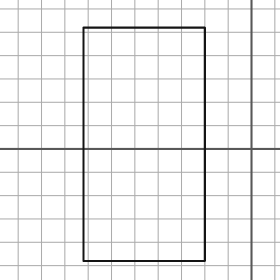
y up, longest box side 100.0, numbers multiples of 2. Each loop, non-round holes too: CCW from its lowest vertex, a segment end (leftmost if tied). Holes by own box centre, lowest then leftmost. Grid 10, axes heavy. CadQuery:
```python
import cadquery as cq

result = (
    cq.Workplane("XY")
    .moveTo(-72.0, -48.0)
    .lineTo(-20.0, -48.0)
    .lineTo(-20.0, 52.0)
    .lineTo(-72.0, 52.0)
    .close()
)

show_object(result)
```